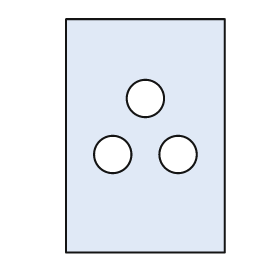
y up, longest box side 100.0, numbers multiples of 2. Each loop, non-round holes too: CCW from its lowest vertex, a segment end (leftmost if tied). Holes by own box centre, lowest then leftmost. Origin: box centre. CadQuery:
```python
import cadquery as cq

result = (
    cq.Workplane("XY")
    .moveTo(-34.0, -50.0)
    .lineTo(34.0, -50.0)
    .lineTo(34.0, 50.0)
    .lineTo(-34.0, 50.0)
    .close()
    .moveTo(-14.0, -8.0)
    .circle(8.0)
    .moveTo(14.0, -8.0)
    .circle(8.0)
    .moveTo(0.0, 16.0)
    .circle(8.0)
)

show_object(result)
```